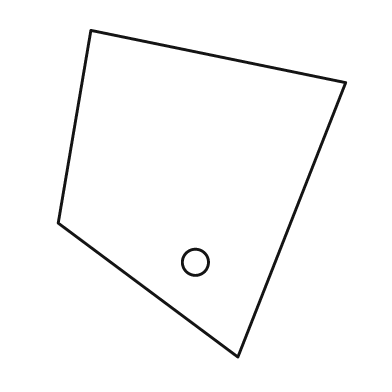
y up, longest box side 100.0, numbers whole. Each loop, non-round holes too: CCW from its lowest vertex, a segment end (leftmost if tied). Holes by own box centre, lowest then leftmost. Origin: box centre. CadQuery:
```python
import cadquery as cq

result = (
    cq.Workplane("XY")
    .moveTo(11.0, -50.0)
    .lineTo(44.0, 34.0)
    .lineTo(-34.0, 50.0)
    .lineTo(-44.0, -9.0)
    .close()
    .moveTo(-2.0, -21.0)
    .circle(4.0)
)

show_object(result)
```